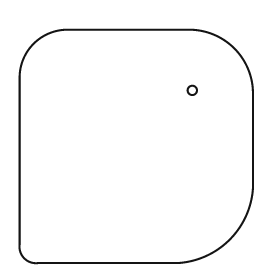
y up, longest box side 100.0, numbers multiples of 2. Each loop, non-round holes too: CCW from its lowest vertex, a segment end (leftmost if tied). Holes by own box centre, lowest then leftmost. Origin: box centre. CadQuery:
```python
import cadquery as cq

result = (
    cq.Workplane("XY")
    .moveTo(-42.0, -50.0)
    .lineTo(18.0, -50.0)
    .threePointArc((40.0, -40.0), (50.0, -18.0))
    .lineTo(50.0, 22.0)
    .threePointArc((42.0, 42.0), (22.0, 50.0))
    .lineTo(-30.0, 50.0)
    .threePointArc((-44.0, 44.0), (-50.0, 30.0))
    .lineTo(-50.0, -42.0)
    .threePointArc((-48.0, -48.0), (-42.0, -50.0))
    .close()
    .moveTo(24.0, 24.0)
    .circle(2.0)
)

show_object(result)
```